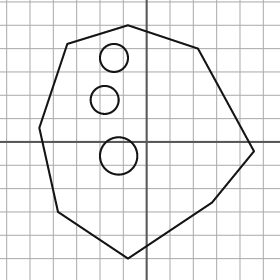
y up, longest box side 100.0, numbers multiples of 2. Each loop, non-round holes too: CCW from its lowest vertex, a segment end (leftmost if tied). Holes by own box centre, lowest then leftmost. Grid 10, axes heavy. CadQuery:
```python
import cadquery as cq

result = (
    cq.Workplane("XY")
    .moveTo(-8.0, -50.0)
    .lineTo(28.0, -26.0)
    .lineTo(46.0, -4.0)
    .lineTo(22.0, 40.0)
    .lineTo(-8.0, 50.0)
    .lineTo(-34.0, 42.0)
    .lineTo(-46.0, 6.0)
    .lineTo(-38.0, -30.0)
    .close()
    .moveTo(-12.0, -6.0)
    .circle(8.0)
    .moveTo(-18.0, 18.0)
    .circle(6.0)
    .moveTo(-14.0, 36.0)
    .circle(6.0)
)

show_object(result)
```